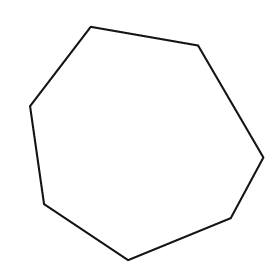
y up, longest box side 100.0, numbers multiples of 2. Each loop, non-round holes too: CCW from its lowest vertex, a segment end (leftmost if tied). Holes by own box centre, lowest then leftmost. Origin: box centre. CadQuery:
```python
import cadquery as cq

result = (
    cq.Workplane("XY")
    .moveTo(-8.0, -50.0)
    .lineTo(36.0, -32.0)
    .lineTo(50.0, -6.0)
    .lineTo(22.0, 42.0)
    .lineTo(-24.0, 50.0)
    .lineTo(-50.0, 16.0)
    .lineTo(-44.0, -26.0)
    .close()
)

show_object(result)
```